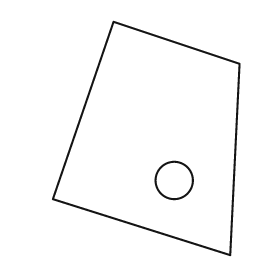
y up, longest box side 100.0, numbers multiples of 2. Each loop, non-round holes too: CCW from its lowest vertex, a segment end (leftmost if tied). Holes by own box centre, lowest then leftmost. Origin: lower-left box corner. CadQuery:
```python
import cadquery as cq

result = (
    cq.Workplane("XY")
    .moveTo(76.0, 0.0)
    .lineTo(80.0, 82.0)
    .lineTo(26.0, 100.0)
    .lineTo(0.0, 24.0)
    .close()
    .moveTo(52.0, 32.0)
    .circle(8.0)
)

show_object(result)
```